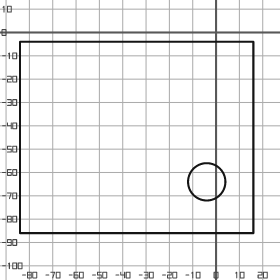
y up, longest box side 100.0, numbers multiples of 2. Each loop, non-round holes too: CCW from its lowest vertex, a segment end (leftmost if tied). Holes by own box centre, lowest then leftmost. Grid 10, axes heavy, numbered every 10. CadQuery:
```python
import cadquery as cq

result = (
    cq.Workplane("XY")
    .moveTo(-84.0, -86.0)
    .lineTo(16.0, -86.0)
    .lineTo(16.0, -4.0)
    .lineTo(-84.0, -4.0)
    .close()
    .moveTo(-4.0, -64.0)
    .circle(8.0)
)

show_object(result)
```